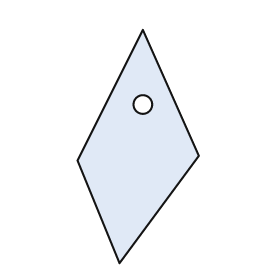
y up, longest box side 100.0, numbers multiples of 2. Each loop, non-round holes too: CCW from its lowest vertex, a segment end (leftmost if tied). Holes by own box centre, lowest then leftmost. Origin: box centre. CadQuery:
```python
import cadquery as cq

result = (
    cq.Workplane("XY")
    .moveTo(-8.0, -50.0)
    .lineTo(26.0, -4.0)
    .lineTo(2.0, 50.0)
    .lineTo(-26.0, -6.0)
    .close()
    .moveTo(2.0, 18.0)
    .circle(4.0)
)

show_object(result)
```